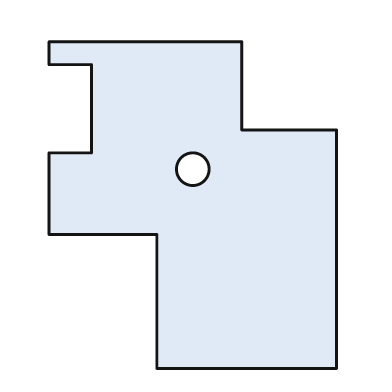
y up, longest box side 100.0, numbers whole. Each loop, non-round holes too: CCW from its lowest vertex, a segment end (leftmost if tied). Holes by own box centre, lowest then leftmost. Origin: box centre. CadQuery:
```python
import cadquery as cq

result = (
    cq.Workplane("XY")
    .moveTo(-11.0, -50.0)
    .lineTo(44.0, -50.0)
    .lineTo(44.0, 23.0)
    .lineTo(15.0, 23.0)
    .lineTo(15.0, 50.0)
    .lineTo(-44.0, 50.0)
    .lineTo(-44.0, 43.0)
    .lineTo(-31.0, 43.0)
    .lineTo(-31.0, 16.0)
    .lineTo(-44.0, 16.0)
    .lineTo(-44.0, -9.0)
    .lineTo(-11.0, -9.0)
    .close()
    .moveTo(0.0, 11.0)
    .circle(5.0)
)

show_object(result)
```